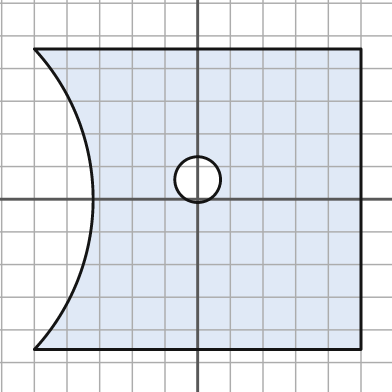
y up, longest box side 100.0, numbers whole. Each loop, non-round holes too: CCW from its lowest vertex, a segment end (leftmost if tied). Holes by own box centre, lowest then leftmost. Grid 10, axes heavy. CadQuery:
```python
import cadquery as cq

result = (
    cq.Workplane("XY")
    .moveTo(-50.0, -46.0)
    .lineTo(50.0, -46.0)
    .lineTo(50.0, 46.0)
    .lineTo(-50.0, 46.0)
    .threePointArc((-32.0, 0.0), (-50.0, -46.0))
    .close()
    .moveTo(0.0, 6.0)
    .circle(7.0)
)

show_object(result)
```